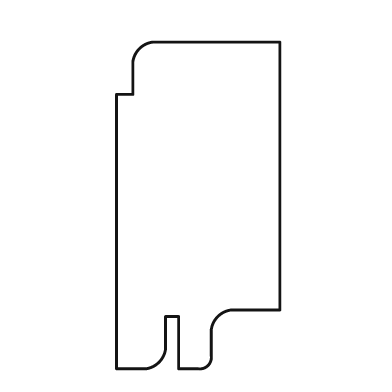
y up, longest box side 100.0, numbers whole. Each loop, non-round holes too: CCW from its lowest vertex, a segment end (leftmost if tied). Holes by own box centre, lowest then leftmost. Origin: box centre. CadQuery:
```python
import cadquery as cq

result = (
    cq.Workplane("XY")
    .moveTo(-25.0, -50.0)
    .lineTo(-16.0, -50.0)
    .threePointArc((-12.0, -48.0), (-10.0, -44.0))
    .lineTo(-10.0, -34.0)
    .lineTo(-6.0, -34.0)
    .lineTo(-6.0, -50.0)
    .lineTo(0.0, -50.0)
    .threePointArc((3.0, -49.0), (4.0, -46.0))
    .lineTo(4.0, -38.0)
    .threePointArc((6.0, -34.0), (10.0, -32.0))
    .lineTo(25.0, -32.0)
    .lineTo(25.0, 50.0)
    .lineTo(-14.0, 50.0)
    .threePointArc((-18.0, 48.0), (-20.0, 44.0))
    .lineTo(-20.0, 34.0)
    .lineTo(-25.0, 34.0)
    .close()
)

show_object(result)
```